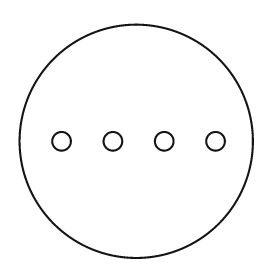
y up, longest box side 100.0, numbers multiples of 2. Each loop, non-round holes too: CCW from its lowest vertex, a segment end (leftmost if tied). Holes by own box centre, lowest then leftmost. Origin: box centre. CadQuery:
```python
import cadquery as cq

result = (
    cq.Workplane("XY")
    .moveTo(0.0, 0.0)
    .circle(50.0)
    .moveTo(-32.0, 0.0)
    .circle(4.0)
    .moveTo(-10.0, 0.0)
    .circle(4.0)
    .moveTo(12.0, 0.0)
    .circle(4.0)
    .moveTo(34.0, 0.0)
    .circle(4.0)
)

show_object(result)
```